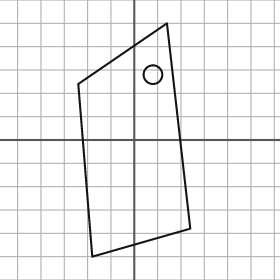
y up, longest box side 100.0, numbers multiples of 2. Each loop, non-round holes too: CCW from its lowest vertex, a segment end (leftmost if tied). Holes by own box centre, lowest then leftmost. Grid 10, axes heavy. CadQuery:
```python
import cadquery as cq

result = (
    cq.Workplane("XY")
    .moveTo(-18.0, -50.0)
    .lineTo(24.0, -38.0)
    .lineTo(14.0, 50.0)
    .lineTo(-24.0, 24.0)
    .close()
    .moveTo(8.0, 28.0)
    .circle(4.0)
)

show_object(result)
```